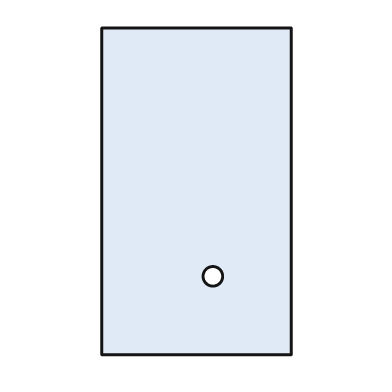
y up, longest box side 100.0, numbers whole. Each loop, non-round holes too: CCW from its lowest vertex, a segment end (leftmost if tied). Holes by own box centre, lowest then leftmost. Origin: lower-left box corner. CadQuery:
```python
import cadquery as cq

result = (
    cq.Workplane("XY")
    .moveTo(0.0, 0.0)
    .lineTo(58.0, 0.0)
    .lineTo(58.0, 100.0)
    .lineTo(0.0, 100.0)
    .close()
    .moveTo(34.0, 24.0)
    .circle(3.0)
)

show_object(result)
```